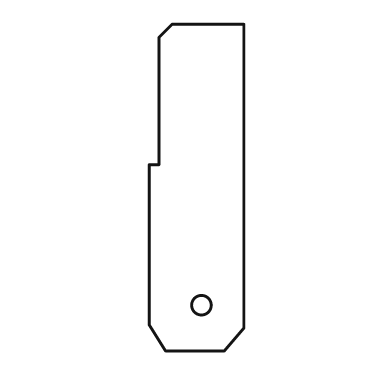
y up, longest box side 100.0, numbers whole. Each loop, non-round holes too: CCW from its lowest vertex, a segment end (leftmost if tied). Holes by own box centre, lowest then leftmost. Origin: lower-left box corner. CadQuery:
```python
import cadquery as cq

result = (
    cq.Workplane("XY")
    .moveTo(5.0, 0.0)
    .lineTo(23.0, 0.0)
    .lineTo(29.0, 7.0)
    .lineTo(29.0, 100.0)
    .lineTo(7.0, 100.0)
    .lineTo(3.0, 96.0)
    .lineTo(3.0, 57.0)
    .lineTo(0.0, 57.0)
    .lineTo(0.0, 8.0)
    .close()
    .moveTo(16.0, 14.0)
    .circle(3.0)
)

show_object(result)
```